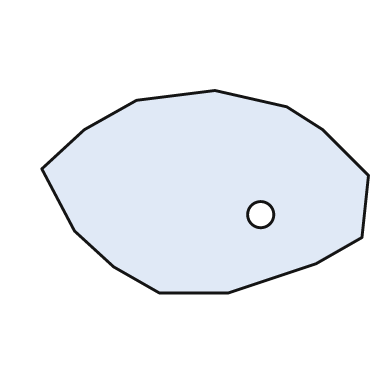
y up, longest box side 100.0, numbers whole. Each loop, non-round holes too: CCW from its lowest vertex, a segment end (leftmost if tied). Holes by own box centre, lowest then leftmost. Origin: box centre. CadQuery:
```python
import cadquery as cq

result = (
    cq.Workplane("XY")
    .moveTo(-14.0, -31.0)
    .lineTo(7.0, -31.0)
    .lineTo(34.0, -22.0)
    .lineTo(48.0, -14.0)
    .lineTo(50.0, 5.0)
    .lineTo(36.0, 19.0)
    .lineTo(25.0, 26.0)
    .lineTo(3.0, 31.0)
    .lineTo(-21.0, 28.0)
    .lineTo(-37.0, 19.0)
    .lineTo(-50.0, 7.0)
    .lineTo(-40.0, -12.0)
    .lineTo(-28.0, -23.0)
    .close()
    .moveTo(17.0, -7.0)
    .circle(4.0)
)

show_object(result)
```